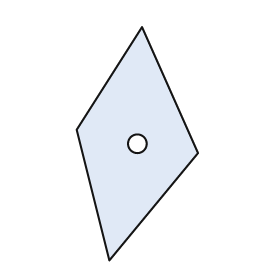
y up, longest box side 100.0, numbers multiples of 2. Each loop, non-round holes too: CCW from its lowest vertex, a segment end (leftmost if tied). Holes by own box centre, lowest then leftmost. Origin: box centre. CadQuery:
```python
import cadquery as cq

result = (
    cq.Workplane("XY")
    .moveTo(-12.0, -50.0)
    .lineTo(26.0, -4.0)
    .lineTo(2.0, 50.0)
    .lineTo(-26.0, 6.0)
    .close()
    .moveTo(0.0, 0.0)
    .circle(4.0)
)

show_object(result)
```